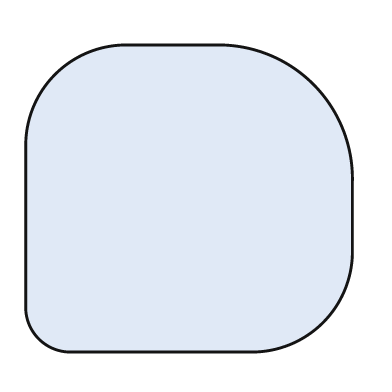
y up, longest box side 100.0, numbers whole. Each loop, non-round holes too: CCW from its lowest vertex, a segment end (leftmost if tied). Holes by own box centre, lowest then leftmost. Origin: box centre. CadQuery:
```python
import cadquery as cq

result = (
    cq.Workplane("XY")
    .moveTo(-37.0, -47.0)
    .lineTo(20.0, -47.0)
    .threePointArc((41.0, -38.0), (50.0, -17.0))
    .lineTo(50.0, 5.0)
    .threePointArc((38.0, 35.0), (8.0, 47.0))
    .lineTo(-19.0, 47.0)
    .threePointArc((-41.0, 38.0), (-50.0, 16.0))
    .lineTo(-50.0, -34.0)
    .threePointArc((-46.0, -43.0), (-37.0, -47.0))
    .close()
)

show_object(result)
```